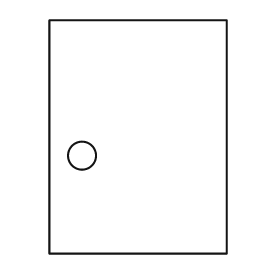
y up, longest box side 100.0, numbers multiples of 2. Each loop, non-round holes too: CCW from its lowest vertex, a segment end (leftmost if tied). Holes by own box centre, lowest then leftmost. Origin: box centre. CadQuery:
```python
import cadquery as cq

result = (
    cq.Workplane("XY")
    .moveTo(-38.0, -50.0)
    .lineTo(38.0, -50.0)
    .lineTo(38.0, 50.0)
    .lineTo(-38.0, 50.0)
    .close()
    .moveTo(-24.0, -8.0)
    .circle(6.0)
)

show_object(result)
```